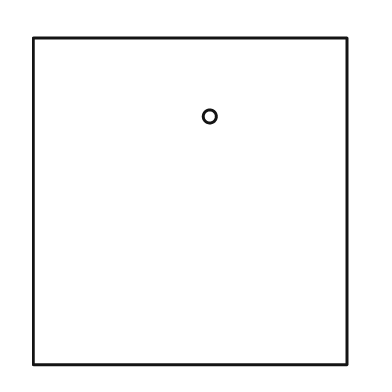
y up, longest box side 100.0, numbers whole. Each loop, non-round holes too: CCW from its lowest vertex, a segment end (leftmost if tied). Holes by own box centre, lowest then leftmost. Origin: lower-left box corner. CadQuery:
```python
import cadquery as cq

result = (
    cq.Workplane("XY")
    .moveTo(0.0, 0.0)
    .lineTo(96.0, 0.0)
    .lineTo(96.0, 100.0)
    .lineTo(0.0, 100.0)
    .close()
    .moveTo(54.0, 76.0)
    .circle(2.0)
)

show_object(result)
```